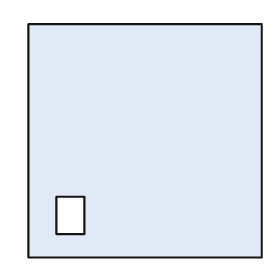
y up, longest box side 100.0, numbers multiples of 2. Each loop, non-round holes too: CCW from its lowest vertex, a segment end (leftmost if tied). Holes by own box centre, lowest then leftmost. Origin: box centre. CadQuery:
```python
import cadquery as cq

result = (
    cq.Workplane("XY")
    .moveTo(-50.0, -50.0)
    .lineTo(50.0, -50.0)
    .lineTo(50.0, 50.0)
    .lineTo(-50.0, 50.0)
    .close()
    .moveTo(-38.0, -40.0)
    .lineTo(-26.0, -40.0)
    .lineTo(-26.0, -24.0)
    .lineTo(-38.0, -24.0)
    .close()
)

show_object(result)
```